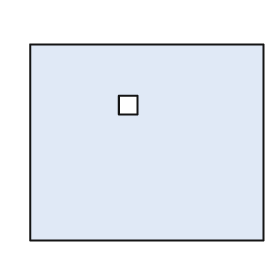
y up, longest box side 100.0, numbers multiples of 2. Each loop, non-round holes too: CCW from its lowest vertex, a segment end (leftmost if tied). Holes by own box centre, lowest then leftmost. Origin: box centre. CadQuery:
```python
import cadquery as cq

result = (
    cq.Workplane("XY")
    .moveTo(-50.0, -42.0)
    .lineTo(50.0, -42.0)
    .lineTo(50.0, 42.0)
    .lineTo(-50.0, 42.0)
    .close()
    .moveTo(-12.0, 12.0)
    .lineTo(-4.0, 12.0)
    .lineTo(-4.0, 20.0)
    .lineTo(-12.0, 20.0)
    .close()
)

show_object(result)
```